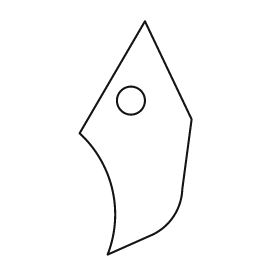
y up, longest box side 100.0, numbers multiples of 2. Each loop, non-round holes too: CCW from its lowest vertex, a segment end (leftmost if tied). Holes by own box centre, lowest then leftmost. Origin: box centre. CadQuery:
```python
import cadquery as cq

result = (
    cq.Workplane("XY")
    .moveTo(-12.0, -50.0)
    .lineTo(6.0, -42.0)
    .threePointArc((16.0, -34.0), (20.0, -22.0))
    .lineTo(24.0, 8.0)
    .lineTo(4.0, 50.0)
    .lineTo(-24.0, 2.0)
    .threePointArc((-10.0, -22.0), (-12.0, -50.0))
    .close()
    .moveTo(-2.0, 16.0)
    .circle(6.0)
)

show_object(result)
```